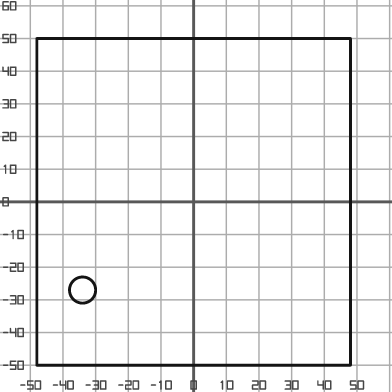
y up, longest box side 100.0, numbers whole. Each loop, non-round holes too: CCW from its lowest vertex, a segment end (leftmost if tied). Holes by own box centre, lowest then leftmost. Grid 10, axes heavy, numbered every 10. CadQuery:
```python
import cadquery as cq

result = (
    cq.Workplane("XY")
    .moveTo(-48.0, -50.0)
    .lineTo(48.0, -50.0)
    .lineTo(48.0, 50.0)
    .lineTo(-48.0, 50.0)
    .close()
    .moveTo(-34.0, -27.0)
    .circle(4.0)
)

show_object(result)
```